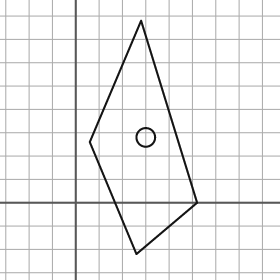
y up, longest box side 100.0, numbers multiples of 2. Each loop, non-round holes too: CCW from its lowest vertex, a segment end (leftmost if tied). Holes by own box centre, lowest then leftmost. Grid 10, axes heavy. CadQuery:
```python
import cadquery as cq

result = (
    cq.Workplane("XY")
    .moveTo(26.0, -22.0)
    .lineTo(52.0, 0.0)
    .lineTo(28.0, 78.0)
    .lineTo(6.0, 26.0)
    .close()
    .moveTo(30.0, 28.0)
    .circle(4.0)
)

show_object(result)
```